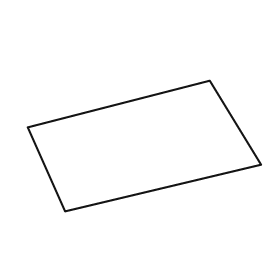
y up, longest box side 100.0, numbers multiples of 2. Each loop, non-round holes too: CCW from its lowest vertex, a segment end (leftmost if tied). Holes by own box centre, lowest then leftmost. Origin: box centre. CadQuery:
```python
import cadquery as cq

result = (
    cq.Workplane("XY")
    .moveTo(-34.0, -28.0)
    .lineTo(50.0, -8.0)
    .lineTo(28.0, 28.0)
    .lineTo(-50.0, 8.0)
    .close()
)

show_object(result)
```